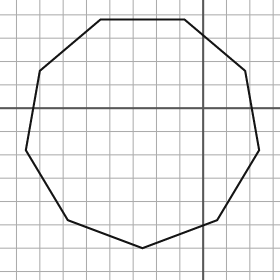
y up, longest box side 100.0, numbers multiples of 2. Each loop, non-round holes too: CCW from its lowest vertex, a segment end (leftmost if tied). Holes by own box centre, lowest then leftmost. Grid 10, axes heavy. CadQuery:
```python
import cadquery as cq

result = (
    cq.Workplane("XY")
    .moveTo(-26.0, -60.0)
    .lineTo(6.0, -48.0)
    .lineTo(24.0, -18.0)
    .lineTo(18.0, 16.0)
    .lineTo(-8.0, 38.0)
    .lineTo(-44.0, 38.0)
    .lineTo(-70.0, 16.0)
    .lineTo(-76.0, -18.0)
    .lineTo(-58.0, -48.0)
    .close()
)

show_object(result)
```